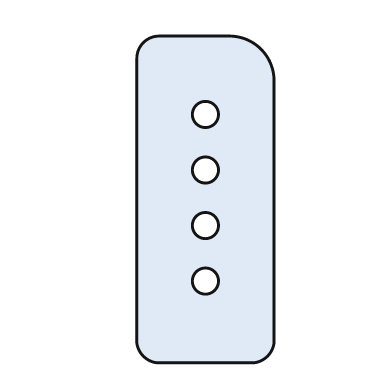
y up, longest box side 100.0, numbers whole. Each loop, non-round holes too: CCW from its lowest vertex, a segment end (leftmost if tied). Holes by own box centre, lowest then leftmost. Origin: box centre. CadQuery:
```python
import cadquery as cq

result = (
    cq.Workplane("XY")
    .moveTo(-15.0, -50.0)
    .lineTo(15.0, -50.0)
    .threePointArc((19.0, -48.0), (21.0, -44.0))
    .lineTo(21.0, 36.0)
    .threePointArc((17.0, 46.0), (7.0, 50.0))
    .lineTo(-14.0, 50.0)
    .threePointArc((-19.0, 48.0), (-21.0, 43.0))
    .lineTo(-21.0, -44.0)
    .threePointArc((-19.0, -48.0), (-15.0, -50.0))
    .close()
    .moveTo(0.0, -25.0)
    .circle(4.0)
    .moveTo(0.0, -8.0)
    .circle(4.0)
    .moveTo(0.0, 9.0)
    .circle(4.0)
    .moveTo(0.0, 26.0)
    .circle(4.0)
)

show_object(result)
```